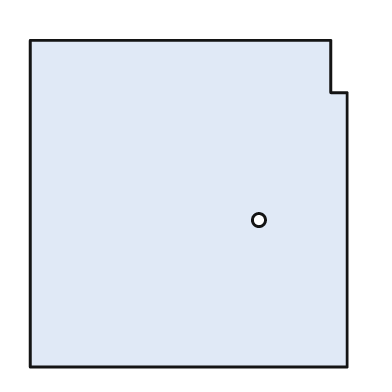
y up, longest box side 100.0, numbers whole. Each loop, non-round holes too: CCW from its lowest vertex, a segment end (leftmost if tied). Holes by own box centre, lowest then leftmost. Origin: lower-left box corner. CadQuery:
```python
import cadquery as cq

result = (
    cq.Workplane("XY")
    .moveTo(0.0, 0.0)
    .lineTo(97.0, 0.0)
    .lineTo(97.0, 84.0)
    .lineTo(92.0, 84.0)
    .lineTo(92.0, 100.0)
    .lineTo(0.0, 100.0)
    .close()
    .moveTo(70.0, 45.0)
    .circle(2.0)
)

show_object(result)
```